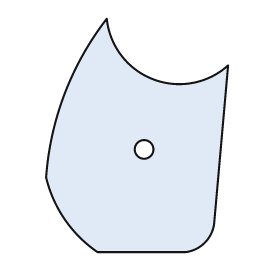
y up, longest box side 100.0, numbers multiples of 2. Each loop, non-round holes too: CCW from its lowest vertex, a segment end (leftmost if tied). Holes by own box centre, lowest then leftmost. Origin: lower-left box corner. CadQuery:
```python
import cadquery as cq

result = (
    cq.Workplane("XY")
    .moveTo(22.0, 0.0)
    .lineTo(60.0, 0.0)
    .threePointArc((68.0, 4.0), (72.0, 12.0))
    .lineTo(78.0, 80.0)
    .threePointArc((46.0, 74.0), (26.0, 100.0))
    .threePointArc((8.0, 68.0), (0.0, 32.0))
    .threePointArc((8.0, 14.0), (22.0, 0.0))
    .close()
    .moveTo(42.0, 44.0)
    .circle(4.0)
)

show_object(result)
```